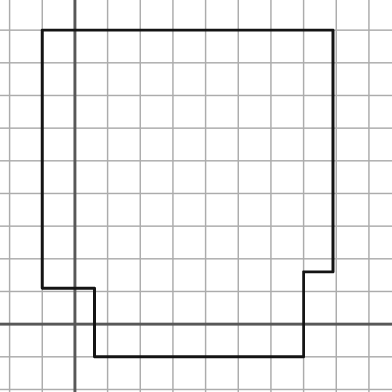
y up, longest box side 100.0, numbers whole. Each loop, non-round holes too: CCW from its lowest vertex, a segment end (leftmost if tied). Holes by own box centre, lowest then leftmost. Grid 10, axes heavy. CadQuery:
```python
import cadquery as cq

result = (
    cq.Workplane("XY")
    .moveTo(6.0, -10.0)
    .lineTo(70.0, -10.0)
    .lineTo(70.0, 16.0)
    .lineTo(79.0, 16.0)
    .lineTo(79.0, 90.0)
    .lineTo(-10.0, 90.0)
    .lineTo(-10.0, 11.0)
    .lineTo(6.0, 11.0)
    .close()
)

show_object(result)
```